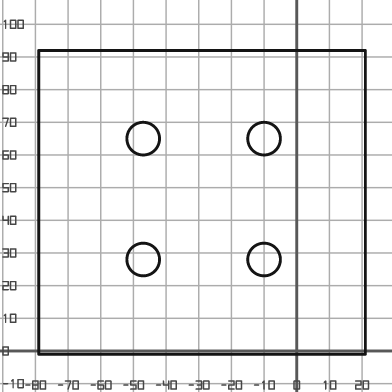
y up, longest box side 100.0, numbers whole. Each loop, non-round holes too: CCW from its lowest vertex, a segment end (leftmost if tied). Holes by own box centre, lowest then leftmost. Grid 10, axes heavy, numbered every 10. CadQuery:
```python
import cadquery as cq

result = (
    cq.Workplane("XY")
    .moveTo(-79.0, -1.0)
    .lineTo(21.0, -1.0)
    .lineTo(21.0, 92.0)
    .lineTo(-79.0, 92.0)
    .close()
    .moveTo(-47.0, 28.0)
    .circle(5.0)
    .moveTo(-10.0, 28.0)
    .circle(5.0)
    .moveTo(-47.0, 65.0)
    .circle(5.0)
    .moveTo(-10.0, 65.0)
    .circle(5.0)
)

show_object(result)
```